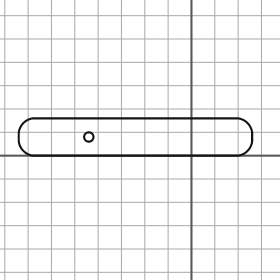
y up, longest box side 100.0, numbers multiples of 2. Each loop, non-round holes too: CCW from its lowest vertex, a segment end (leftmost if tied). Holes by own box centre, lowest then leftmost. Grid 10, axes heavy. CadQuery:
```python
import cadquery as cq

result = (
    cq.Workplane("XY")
    .moveTo(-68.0, 0.0)
    .lineTo(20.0, 0.0)
    .threePointArc((24.0, 2.0), (26.0, 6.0))
    .lineTo(26.0, 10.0)
    .threePointArc((24.0, 14.0), (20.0, 16.0))
    .lineTo(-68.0, 16.0)
    .threePointArc((-72.0, 14.0), (-74.0, 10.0))
    .lineTo(-74.0, 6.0)
    .threePointArc((-72.0, 2.0), (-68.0, 0.0))
    .close()
    .moveTo(-44.0, 8.0)
    .circle(2.0)
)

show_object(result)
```